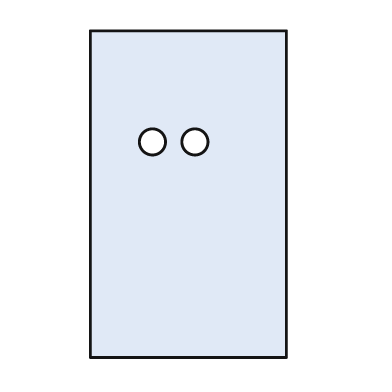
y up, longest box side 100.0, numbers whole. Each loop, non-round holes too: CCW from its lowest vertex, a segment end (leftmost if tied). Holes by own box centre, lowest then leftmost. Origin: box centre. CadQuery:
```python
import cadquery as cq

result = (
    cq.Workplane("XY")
    .moveTo(-30.0, -50.0)
    .lineTo(30.0, -50.0)
    .lineTo(30.0, 50.0)
    .lineTo(-30.0, 50.0)
    .close()
    .moveTo(-11.0, 16.0)
    .circle(4.0)
    .moveTo(2.0, 16.0)
    .circle(4.0)
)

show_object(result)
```